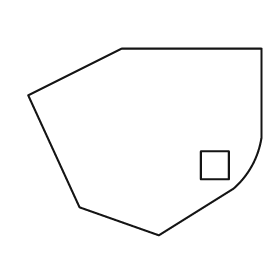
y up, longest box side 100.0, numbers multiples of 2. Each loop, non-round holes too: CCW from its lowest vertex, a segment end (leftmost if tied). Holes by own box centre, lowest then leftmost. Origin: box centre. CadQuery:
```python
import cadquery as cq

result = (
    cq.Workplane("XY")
    .moveTo(6.0, -40.0)
    .lineTo(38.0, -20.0)
    .threePointArc((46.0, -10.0), (50.0, 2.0))
    .lineTo(50.0, 40.0)
    .lineTo(-10.0, 40.0)
    .lineTo(-50.0, 20.0)
    .lineTo(-28.0, -28.0)
    .close()
    .moveTo(24.0, -16.0)
    .lineTo(36.0, -16.0)
    .lineTo(36.0, -4.0)
    .lineTo(24.0, -4.0)
    .close()
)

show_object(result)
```